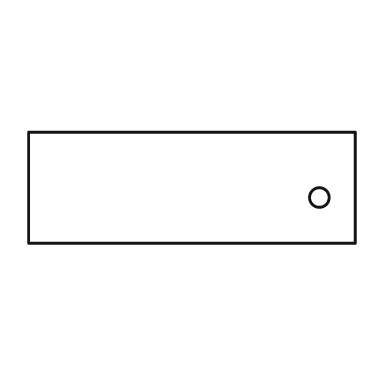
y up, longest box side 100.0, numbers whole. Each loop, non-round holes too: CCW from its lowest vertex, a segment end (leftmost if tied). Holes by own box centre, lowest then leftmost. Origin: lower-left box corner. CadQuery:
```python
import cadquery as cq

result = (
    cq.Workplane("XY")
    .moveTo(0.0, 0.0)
    .lineTo(100.0, 0.0)
    .lineTo(100.0, 34.0)
    .lineTo(0.0, 34.0)
    .close()
    .moveTo(89.0, 14.0)
    .circle(3.0)
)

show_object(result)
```